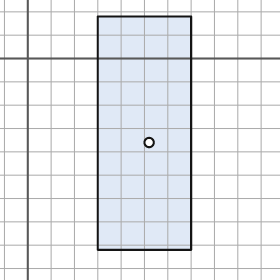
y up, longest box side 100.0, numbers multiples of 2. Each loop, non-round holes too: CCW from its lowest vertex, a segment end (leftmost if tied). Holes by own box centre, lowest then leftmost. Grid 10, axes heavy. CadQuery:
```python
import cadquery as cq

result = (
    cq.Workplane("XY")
    .moveTo(30.0, -82.0)
    .lineTo(70.0, -82.0)
    .lineTo(70.0, 18.0)
    .lineTo(30.0, 18.0)
    .close()
    .moveTo(52.0, -36.0)
    .circle(2.0)
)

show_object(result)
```